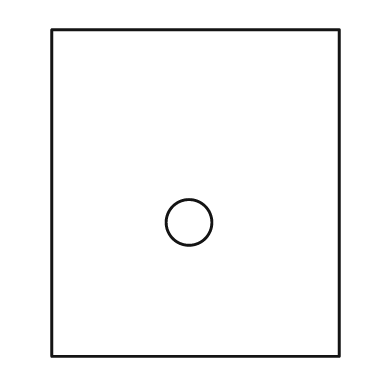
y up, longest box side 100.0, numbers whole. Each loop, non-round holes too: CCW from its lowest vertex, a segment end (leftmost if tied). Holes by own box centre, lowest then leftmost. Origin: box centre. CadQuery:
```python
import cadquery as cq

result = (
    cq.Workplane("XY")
    .moveTo(-44.0, -50.0)
    .lineTo(44.0, -50.0)
    .lineTo(44.0, 50.0)
    .lineTo(-44.0, 50.0)
    .close()
    .moveTo(-2.0, -9.0)
    .circle(7.0)
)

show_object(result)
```